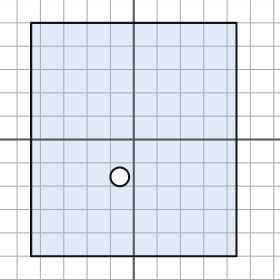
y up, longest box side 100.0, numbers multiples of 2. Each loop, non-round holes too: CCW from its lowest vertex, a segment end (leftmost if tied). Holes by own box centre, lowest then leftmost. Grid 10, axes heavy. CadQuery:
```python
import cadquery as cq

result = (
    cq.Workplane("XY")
    .moveTo(-44.0, -50.0)
    .lineTo(44.0, -50.0)
    .lineTo(44.0, 50.0)
    .lineTo(-44.0, 50.0)
    .close()
    .moveTo(-6.0, -16.0)
    .circle(4.0)
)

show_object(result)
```